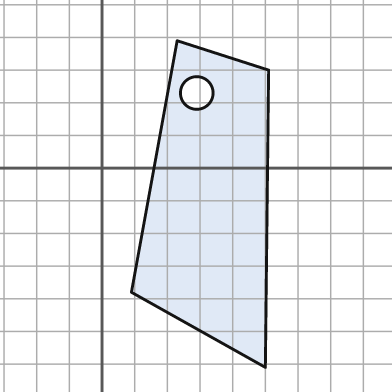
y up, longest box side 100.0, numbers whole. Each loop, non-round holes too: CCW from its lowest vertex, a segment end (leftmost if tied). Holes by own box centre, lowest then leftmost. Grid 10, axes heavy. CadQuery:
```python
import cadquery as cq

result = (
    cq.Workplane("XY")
    .moveTo(50.0, -61.0)
    .lineTo(51.0, 30.0)
    .lineTo(23.0, 39.0)
    .lineTo(9.0, -38.0)
    .close()
    .moveTo(29.0, 23.0)
    .circle(5.0)
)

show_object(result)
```